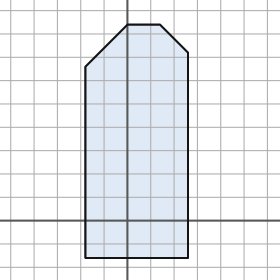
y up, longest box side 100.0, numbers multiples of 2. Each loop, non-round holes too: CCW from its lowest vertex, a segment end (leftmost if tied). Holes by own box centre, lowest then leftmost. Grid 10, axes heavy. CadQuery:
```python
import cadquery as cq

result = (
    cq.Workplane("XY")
    .moveTo(-18.0, -16.0)
    .lineTo(26.0, -16.0)
    .lineTo(26.0, 72.0)
    .lineTo(14.0, 84.0)
    .lineTo(0.0, 84.0)
    .lineTo(-18.0, 66.0)
    .close()
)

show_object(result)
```